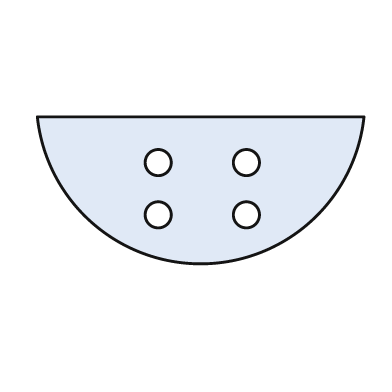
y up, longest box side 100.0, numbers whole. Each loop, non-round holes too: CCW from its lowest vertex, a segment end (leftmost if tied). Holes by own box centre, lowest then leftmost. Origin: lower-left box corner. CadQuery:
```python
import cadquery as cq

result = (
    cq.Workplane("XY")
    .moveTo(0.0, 45.0)
    .threePointArc((50.0, 0.0), (100.0, 45.0))
    .close()
    .moveTo(37.0, 15.0)
    .circle(4.0)
    .moveTo(64.0, 15.0)
    .circle(4.0)
    .moveTo(37.0, 31.0)
    .circle(4.0)
    .moveTo(64.0, 31.0)
    .circle(4.0)
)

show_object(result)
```